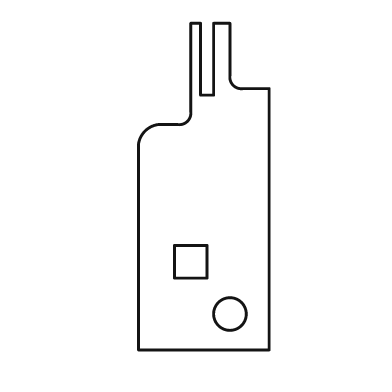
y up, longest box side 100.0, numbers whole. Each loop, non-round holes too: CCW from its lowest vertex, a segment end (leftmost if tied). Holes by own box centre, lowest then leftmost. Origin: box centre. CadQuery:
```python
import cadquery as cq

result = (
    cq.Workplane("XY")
    .moveTo(-20.0, -50.0)
    .lineTo(20.0, -50.0)
    .lineTo(20.0, 30.0)
    .lineTo(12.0, 30.0)
    .threePointArc((9.0, 31.0), (8.0, 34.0))
    .lineTo(8.0, 50.0)
    .lineTo(3.0, 50.0)
    .lineTo(3.0, 28.0)
    .lineTo(-1.0, 28.0)
    .lineTo(-1.0, 50.0)
    .lineTo(-4.0, 50.0)
    .lineTo(-4.0, 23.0)
    .threePointArc((-5.0, 20.0), (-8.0, 19.0))
    .lineTo(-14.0, 19.0)
    .threePointArc((-18.0, 17.0), (-20.0, 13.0))
    .close()
    .moveTo(8.0, -39.0)
    .circle(5.0)
    .moveTo(-9.0, -28.0)
    .lineTo(1.0, -28.0)
    .lineTo(1.0, -18.0)
    .lineTo(-9.0, -18.0)
    .close()
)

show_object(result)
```